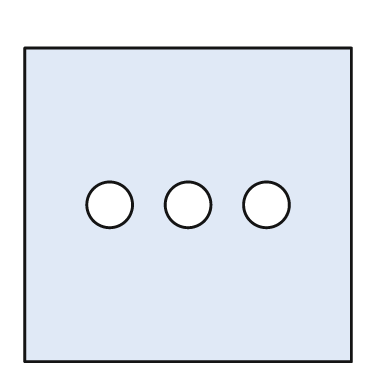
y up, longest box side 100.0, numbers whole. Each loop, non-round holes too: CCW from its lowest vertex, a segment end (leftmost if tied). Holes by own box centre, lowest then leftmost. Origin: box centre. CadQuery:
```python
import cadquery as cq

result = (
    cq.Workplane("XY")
    .moveTo(-50.0, -48.0)
    .lineTo(50.0, -48.0)
    .lineTo(50.0, 48.0)
    .lineTo(-50.0, 48.0)
    .close()
    .moveTo(-24.0, 0.0)
    .circle(7.0)
    .moveTo(0.0, 0.0)
    .circle(7.0)
    .moveTo(24.0, 0.0)
    .circle(7.0)
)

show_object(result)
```